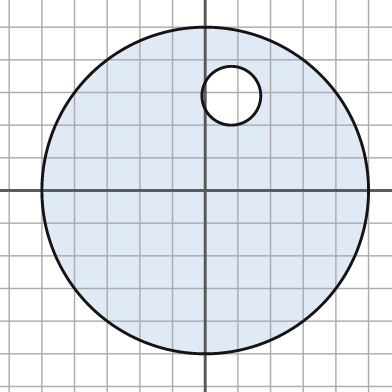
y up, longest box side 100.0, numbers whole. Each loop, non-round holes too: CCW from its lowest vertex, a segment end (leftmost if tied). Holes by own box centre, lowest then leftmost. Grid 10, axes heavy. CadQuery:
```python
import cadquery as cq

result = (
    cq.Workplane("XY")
    .moveTo(0.0, 0.0)
    .circle(50.0)
    .moveTo(8.0, 29.0)
    .circle(9.0)
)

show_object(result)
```